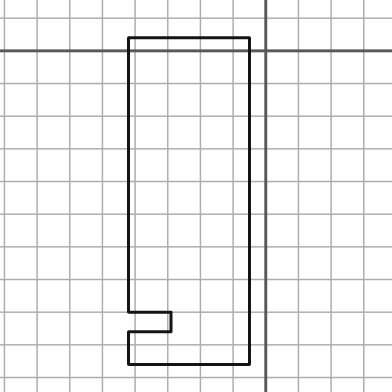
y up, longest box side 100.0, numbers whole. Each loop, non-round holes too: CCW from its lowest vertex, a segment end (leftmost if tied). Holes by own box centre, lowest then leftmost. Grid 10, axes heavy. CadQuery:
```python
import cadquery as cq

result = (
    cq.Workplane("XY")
    .moveTo(-42.0, -96.0)
    .lineTo(-5.0, -96.0)
    .lineTo(-5.0, 4.0)
    .lineTo(-42.0, 4.0)
    .lineTo(-42.0, -80.0)
    .lineTo(-29.0, -80.0)
    .lineTo(-29.0, -86.0)
    .lineTo(-42.0, -86.0)
    .close()
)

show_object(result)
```